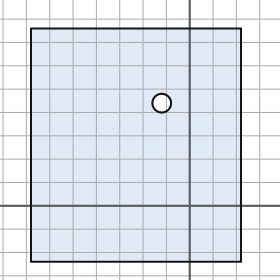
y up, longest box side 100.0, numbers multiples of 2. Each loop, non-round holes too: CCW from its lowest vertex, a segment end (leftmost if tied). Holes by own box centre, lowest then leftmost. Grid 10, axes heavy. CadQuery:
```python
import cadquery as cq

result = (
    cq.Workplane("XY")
    .moveTo(-68.0, -24.0)
    .lineTo(22.0, -24.0)
    .lineTo(22.0, 76.0)
    .lineTo(-68.0, 76.0)
    .close()
    .moveTo(-12.0, 44.0)
    .circle(4.0)
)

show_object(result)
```